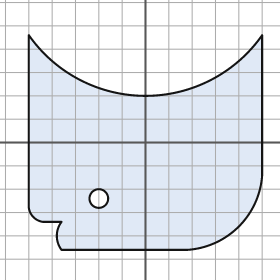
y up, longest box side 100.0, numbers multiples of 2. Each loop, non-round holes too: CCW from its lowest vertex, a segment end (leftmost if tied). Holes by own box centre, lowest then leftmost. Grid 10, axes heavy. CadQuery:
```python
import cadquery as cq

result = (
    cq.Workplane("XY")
    .moveTo(-36.0, -46.0)
    .lineTo(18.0, -46.0)
    .threePointArc((40.0, -36.0), (50.0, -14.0))
    .lineTo(50.0, 46.0)
    .threePointArc((0.0, 20.0), (-50.0, 46.0))
    .lineTo(-50.0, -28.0)
    .threePointArc((-48.0, -32.0), (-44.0, -34.0))
    .lineTo(-36.0, -34.0)
    .threePointArc((-38.0, -40.0), (-36.0, -46.0))
    .close()
    .moveTo(-20.0, -24.0)
    .circle(4.0)
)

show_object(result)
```